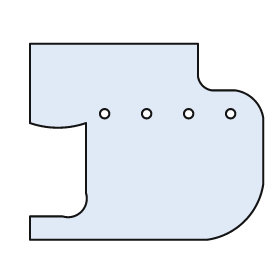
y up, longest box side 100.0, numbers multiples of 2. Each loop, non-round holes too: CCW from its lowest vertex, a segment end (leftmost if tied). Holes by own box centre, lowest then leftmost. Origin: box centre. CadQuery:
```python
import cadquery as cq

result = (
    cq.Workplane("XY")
    .moveTo(-50.0, -42.0)
    .lineTo(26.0, -42.0)
    .threePointArc((42.0, -34.0), (50.0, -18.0))
    .lineTo(50.0, 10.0)
    .threePointArc((46.0, 18.0), (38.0, 22.0))
    .lineTo(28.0, 22.0)
    .threePointArc((24.0, 24.0), (22.0, 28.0))
    .lineTo(22.0, 42.0)
    .lineTo(-50.0, 42.0)
    .lineTo(-50.0, 8.0)
    .threePointArc((-38.0, 6.0), (-26.0, 8.0))
    .lineTo(-26.0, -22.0)
    .threePointArc((-28.0, -30.0), (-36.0, -32.0))
    .lineTo(-50.0, -32.0)
    .close()
    .moveTo(-18.0, 12.0)
    .circle(2.0)
    .moveTo(0.0, 12.0)
    .circle(2.0)
    .moveTo(18.0, 12.0)
    .circle(2.0)
    .moveTo(36.0, 12.0)
    .circle(2.0)
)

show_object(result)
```